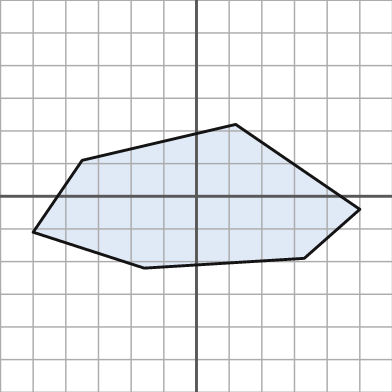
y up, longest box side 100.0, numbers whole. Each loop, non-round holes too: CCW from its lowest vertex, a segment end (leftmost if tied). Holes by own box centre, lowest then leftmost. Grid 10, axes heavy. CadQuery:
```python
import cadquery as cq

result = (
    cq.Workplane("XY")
    .moveTo(-16.0, -22.0)
    .lineTo(33.0, -19.0)
    .lineTo(50.0, -4.0)
    .lineTo(12.0, 22.0)
    .lineTo(-35.0, 11.0)
    .lineTo(-50.0, -11.0)
    .close()
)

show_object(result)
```